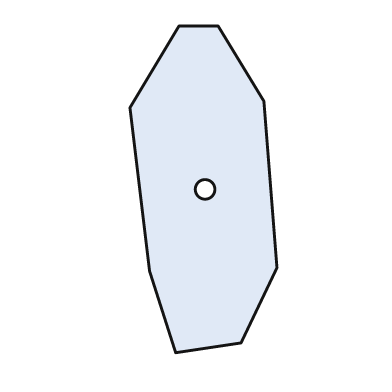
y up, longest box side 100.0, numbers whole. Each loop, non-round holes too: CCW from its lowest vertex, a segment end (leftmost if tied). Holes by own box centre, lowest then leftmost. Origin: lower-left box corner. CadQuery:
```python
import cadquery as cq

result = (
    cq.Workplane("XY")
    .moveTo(14.0, 0.0)
    .lineTo(34.0, 3.0)
    .lineTo(45.0, 26.0)
    .lineTo(41.0, 77.0)
    .lineTo(27.0, 100.0)
    .lineTo(15.0, 100.0)
    .lineTo(0.0, 75.0)
    .lineTo(6.0, 25.0)
    .close()
    .moveTo(23.0, 50.0)
    .circle(3.0)
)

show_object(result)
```